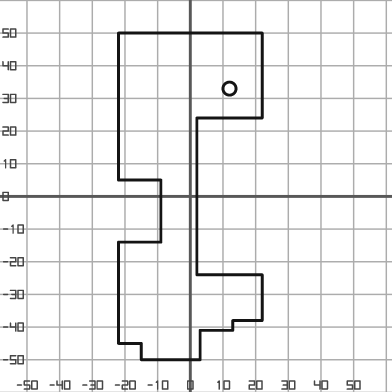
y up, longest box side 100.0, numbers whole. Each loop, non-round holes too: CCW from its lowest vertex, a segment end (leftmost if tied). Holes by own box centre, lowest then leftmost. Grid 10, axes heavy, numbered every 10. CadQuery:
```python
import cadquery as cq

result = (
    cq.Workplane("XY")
    .moveTo(-15.0, -50.0)
    .lineTo(3.0, -50.0)
    .lineTo(3.0, -41.0)
    .lineTo(13.0, -41.0)
    .lineTo(13.0, -38.0)
    .lineTo(22.0, -38.0)
    .lineTo(22.0, -24.0)
    .lineTo(2.0, -24.0)
    .lineTo(2.0, 24.0)
    .lineTo(22.0, 24.0)
    .lineTo(22.0, 50.0)
    .lineTo(-22.0, 50.0)
    .lineTo(-22.0, 5.0)
    .lineTo(-9.0, 5.0)
    .lineTo(-9.0, -14.0)
    .lineTo(-22.0, -14.0)
    .lineTo(-22.0, -45.0)
    .lineTo(-15.0, -45.0)
    .close()
    .moveTo(12.0, 33.0)
    .circle(2.0)
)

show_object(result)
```